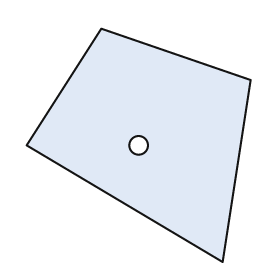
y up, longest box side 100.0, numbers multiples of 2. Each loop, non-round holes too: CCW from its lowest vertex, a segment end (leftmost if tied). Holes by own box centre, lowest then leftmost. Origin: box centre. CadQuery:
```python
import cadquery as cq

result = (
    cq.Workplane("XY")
    .moveTo(36.0, -50.0)
    .lineTo(48.0, 28.0)
    .lineTo(-16.0, 50.0)
    .lineTo(-48.0, 0.0)
    .close()
    .moveTo(0.0, 0.0)
    .circle(4.0)
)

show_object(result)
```